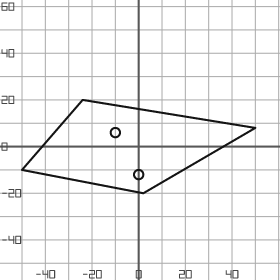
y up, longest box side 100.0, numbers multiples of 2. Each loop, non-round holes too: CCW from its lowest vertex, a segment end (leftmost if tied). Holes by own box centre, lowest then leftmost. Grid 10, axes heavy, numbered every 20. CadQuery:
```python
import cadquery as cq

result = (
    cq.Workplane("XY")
    .moveTo(2.0, -20.0)
    .lineTo(50.0, 8.0)
    .lineTo(-24.0, 20.0)
    .lineTo(-50.0, -10.0)
    .close()
    .moveTo(0.0, -12.0)
    .circle(2.0)
    .moveTo(-10.0, 6.0)
    .circle(2.0)
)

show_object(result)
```